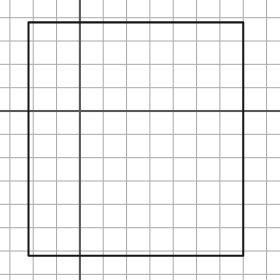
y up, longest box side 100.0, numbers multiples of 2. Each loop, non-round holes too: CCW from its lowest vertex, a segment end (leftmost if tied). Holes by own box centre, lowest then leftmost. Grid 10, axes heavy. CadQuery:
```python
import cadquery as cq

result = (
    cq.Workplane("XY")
    .moveTo(-22.0, -62.0)
    .lineTo(70.0, -62.0)
    .lineTo(70.0, 38.0)
    .lineTo(-22.0, 38.0)
    .close()
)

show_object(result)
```